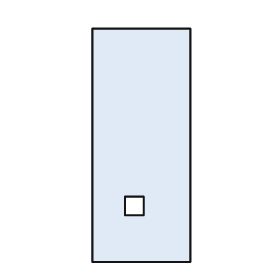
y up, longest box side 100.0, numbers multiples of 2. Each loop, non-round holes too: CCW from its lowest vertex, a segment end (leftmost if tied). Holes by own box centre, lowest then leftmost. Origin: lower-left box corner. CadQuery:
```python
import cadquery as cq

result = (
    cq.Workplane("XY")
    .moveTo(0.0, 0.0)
    .lineTo(42.0, 0.0)
    .lineTo(42.0, 100.0)
    .lineTo(0.0, 100.0)
    .close()
    .moveTo(14.0, 20.0)
    .lineTo(22.0, 20.0)
    .lineTo(22.0, 28.0)
    .lineTo(14.0, 28.0)
    .close()
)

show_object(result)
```